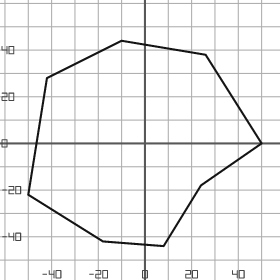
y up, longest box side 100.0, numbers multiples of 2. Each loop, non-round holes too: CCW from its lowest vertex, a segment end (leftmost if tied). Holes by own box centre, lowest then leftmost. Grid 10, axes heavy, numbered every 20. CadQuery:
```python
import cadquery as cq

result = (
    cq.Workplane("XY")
    .moveTo(8.0, -44.0)
    .lineTo(24.0, -18.0)
    .lineTo(50.0, 0.0)
    .lineTo(26.0, 38.0)
    .lineTo(-10.0, 44.0)
    .lineTo(-42.0, 28.0)
    .lineTo(-50.0, -22.0)
    .lineTo(-18.0, -42.0)
    .close()
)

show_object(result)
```